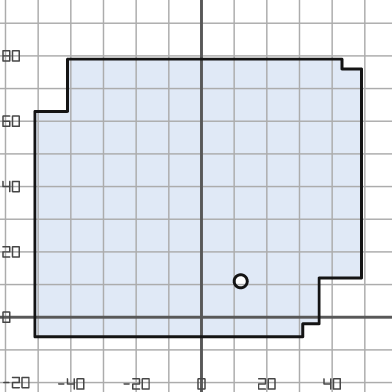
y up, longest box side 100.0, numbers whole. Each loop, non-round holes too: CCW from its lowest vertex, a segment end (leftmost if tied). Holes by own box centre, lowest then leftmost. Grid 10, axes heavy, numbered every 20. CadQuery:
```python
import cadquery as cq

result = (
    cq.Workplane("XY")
    .moveTo(-51.0, -6.0)
    .lineTo(31.0, -6.0)
    .lineTo(31.0, -2.0)
    .lineTo(36.0, -2.0)
    .lineTo(36.0, 12.0)
    .lineTo(49.0, 12.0)
    .lineTo(49.0, 76.0)
    .lineTo(43.0, 76.0)
    .lineTo(43.0, 79.0)
    .lineTo(-41.0, 79.0)
    .lineTo(-41.0, 63.0)
    .lineTo(-51.0, 63.0)
    .close()
    .moveTo(12.0, 11.0)
    .circle(2.0)
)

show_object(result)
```